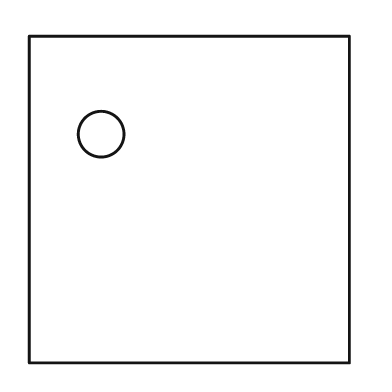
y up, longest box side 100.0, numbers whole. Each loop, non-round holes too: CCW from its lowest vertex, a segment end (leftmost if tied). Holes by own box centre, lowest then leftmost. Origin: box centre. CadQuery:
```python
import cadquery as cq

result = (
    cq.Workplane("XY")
    .moveTo(-49.0, -50.0)
    .lineTo(49.0, -50.0)
    .lineTo(49.0, 50.0)
    .lineTo(-49.0, 50.0)
    .close()
    .moveTo(-27.0, 20.0)
    .circle(7.0)
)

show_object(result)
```